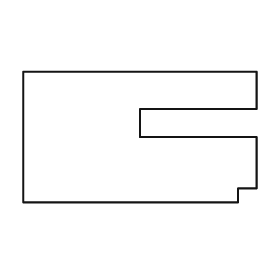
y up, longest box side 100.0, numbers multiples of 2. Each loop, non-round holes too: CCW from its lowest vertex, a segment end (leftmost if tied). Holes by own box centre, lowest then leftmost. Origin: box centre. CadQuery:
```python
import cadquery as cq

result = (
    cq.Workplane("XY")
    .moveTo(-50.0, -28.0)
    .lineTo(42.0, -28.0)
    .lineTo(42.0, -22.0)
    .lineTo(50.0, -22.0)
    .lineTo(50.0, 0.0)
    .lineTo(0.0, 0.0)
    .lineTo(0.0, 12.0)
    .lineTo(50.0, 12.0)
    .lineTo(50.0, 28.0)
    .lineTo(-50.0, 28.0)
    .close()
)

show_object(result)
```